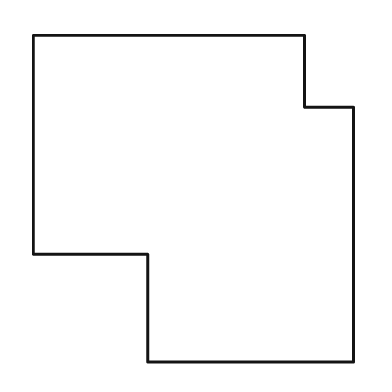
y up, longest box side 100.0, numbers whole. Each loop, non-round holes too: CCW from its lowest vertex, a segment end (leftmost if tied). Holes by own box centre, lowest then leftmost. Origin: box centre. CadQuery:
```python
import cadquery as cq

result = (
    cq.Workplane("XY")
    .moveTo(-14.0, -50.0)
    .lineTo(49.0, -50.0)
    .lineTo(49.0, 28.0)
    .lineTo(34.0, 28.0)
    .lineTo(34.0, 50.0)
    .lineTo(-49.0, 50.0)
    .lineTo(-49.0, -17.0)
    .lineTo(-14.0, -17.0)
    .close()
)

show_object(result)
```